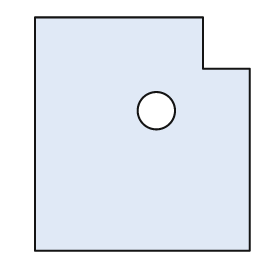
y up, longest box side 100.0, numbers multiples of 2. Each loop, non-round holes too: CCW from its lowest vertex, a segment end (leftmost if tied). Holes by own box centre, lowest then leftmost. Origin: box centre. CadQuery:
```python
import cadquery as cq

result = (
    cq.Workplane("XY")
    .moveTo(-46.0, -50.0)
    .lineTo(46.0, -50.0)
    .lineTo(46.0, 28.0)
    .lineTo(26.0, 28.0)
    .lineTo(26.0, 50.0)
    .lineTo(-46.0, 50.0)
    .close()
    .moveTo(6.0, 10.0)
    .circle(8.0)
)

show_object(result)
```